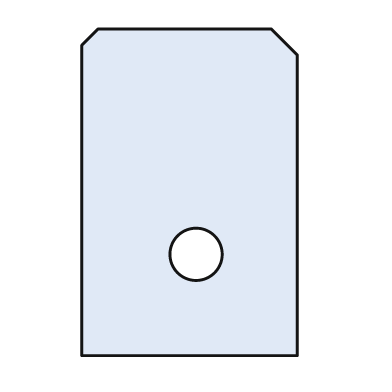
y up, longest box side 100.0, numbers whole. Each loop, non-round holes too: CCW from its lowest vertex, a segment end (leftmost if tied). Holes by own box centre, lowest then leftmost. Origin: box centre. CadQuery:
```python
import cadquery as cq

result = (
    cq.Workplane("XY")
    .moveTo(-33.0, -50.0)
    .lineTo(33.0, -50.0)
    .lineTo(33.0, 42.0)
    .lineTo(25.0, 50.0)
    .lineTo(-28.0, 50.0)
    .lineTo(-33.0, 45.0)
    .close()
    .moveTo(2.0, -19.0)
    .circle(8.0)
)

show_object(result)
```